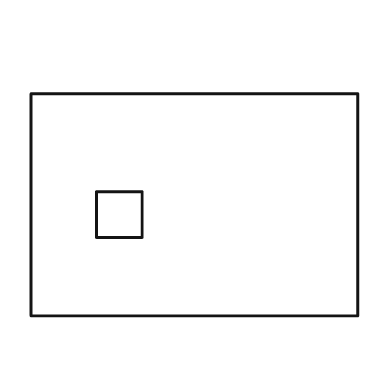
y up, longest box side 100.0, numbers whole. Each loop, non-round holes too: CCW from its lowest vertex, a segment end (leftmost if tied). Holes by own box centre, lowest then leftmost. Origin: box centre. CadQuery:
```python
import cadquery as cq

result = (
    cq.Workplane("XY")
    .moveTo(-50.0, -34.0)
    .lineTo(50.0, -34.0)
    .lineTo(50.0, 34.0)
    .lineTo(-50.0, 34.0)
    .close()
    .moveTo(-30.0, -10.0)
    .lineTo(-16.0, -10.0)
    .lineTo(-16.0, 4.0)
    .lineTo(-30.0, 4.0)
    .close()
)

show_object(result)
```